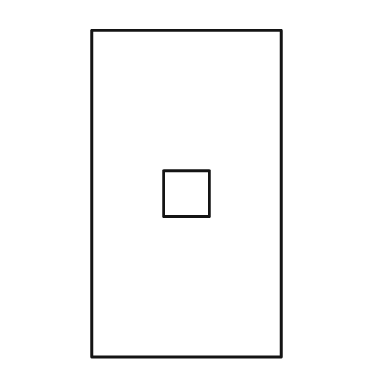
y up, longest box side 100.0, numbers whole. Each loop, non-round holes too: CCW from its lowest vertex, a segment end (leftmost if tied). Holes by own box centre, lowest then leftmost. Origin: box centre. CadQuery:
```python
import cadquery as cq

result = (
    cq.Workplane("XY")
    .moveTo(-29.0, -50.0)
    .lineTo(29.0, -50.0)
    .lineTo(29.0, 50.0)
    .lineTo(-29.0, 50.0)
    .close()
    .moveTo(-7.0, -7.0)
    .lineTo(7.0, -7.0)
    .lineTo(7.0, 7.0)
    .lineTo(-7.0, 7.0)
    .close()
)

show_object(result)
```